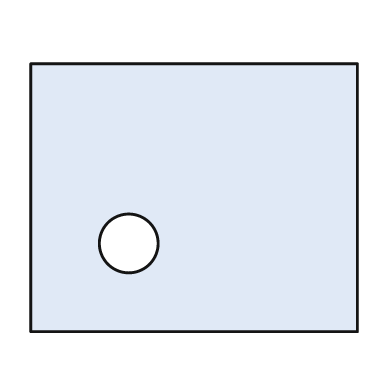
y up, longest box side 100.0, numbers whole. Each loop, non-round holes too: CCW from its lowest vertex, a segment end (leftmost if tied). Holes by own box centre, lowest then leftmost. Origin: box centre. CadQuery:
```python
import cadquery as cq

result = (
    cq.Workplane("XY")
    .moveTo(-50.0, -41.0)
    .lineTo(50.0, -41.0)
    .lineTo(50.0, 41.0)
    .lineTo(-50.0, 41.0)
    .close()
    .moveTo(-20.0, -14.0)
    .circle(9.0)
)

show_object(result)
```